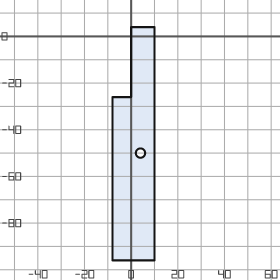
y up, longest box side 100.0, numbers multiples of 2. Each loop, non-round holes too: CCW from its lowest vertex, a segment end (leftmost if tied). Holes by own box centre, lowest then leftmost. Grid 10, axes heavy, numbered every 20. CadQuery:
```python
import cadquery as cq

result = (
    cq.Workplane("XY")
    .moveTo(-8.0, -96.0)
    .lineTo(10.0, -96.0)
    .lineTo(10.0, 4.0)
    .lineTo(0.0, 4.0)
    .lineTo(0.0, -26.0)
    .lineTo(-8.0, -26.0)
    .close()
    .moveTo(4.0, -50.0)
    .circle(2.0)
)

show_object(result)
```